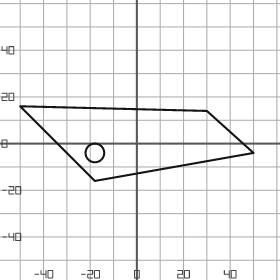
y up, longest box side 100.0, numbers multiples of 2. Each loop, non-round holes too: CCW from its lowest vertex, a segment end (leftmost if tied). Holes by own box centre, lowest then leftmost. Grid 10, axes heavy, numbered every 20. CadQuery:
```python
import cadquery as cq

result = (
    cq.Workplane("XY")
    .moveTo(-18.0, -16.0)
    .lineTo(50.0, -4.0)
    .lineTo(30.0, 14.0)
    .lineTo(-50.0, 16.0)
    .close()
    .moveTo(-18.0, -4.0)
    .circle(4.0)
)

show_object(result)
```